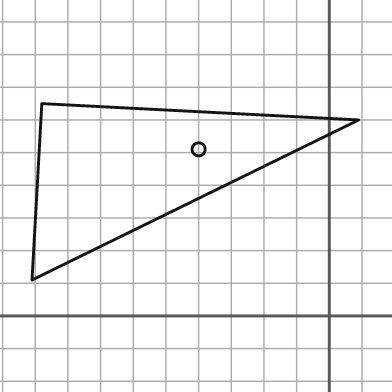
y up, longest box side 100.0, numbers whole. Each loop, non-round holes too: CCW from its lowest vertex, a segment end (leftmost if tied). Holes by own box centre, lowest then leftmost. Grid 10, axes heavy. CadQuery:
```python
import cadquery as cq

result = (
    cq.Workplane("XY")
    .moveTo(-91.0, 11.0)
    .lineTo(9.0, 60.0)
    .lineTo(-88.0, 65.0)
    .close()
    .moveTo(-40.0, 51.0)
    .circle(2.0)
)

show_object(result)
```